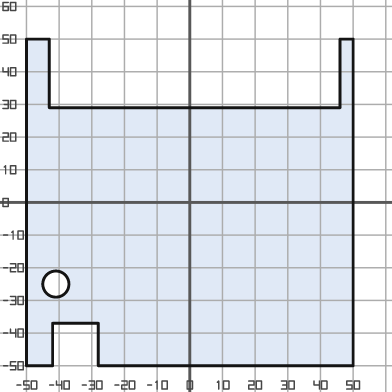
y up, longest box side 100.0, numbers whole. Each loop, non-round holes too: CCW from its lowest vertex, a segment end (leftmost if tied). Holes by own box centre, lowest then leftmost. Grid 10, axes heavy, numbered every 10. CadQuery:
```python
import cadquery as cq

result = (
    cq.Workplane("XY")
    .moveTo(-50.0, -50.0)
    .lineTo(-42.0, -50.0)
    .lineTo(-42.0, -37.0)
    .lineTo(-28.0, -37.0)
    .lineTo(-28.0, -50.0)
    .lineTo(50.0, -50.0)
    .lineTo(50.0, 50.0)
    .lineTo(46.0, 50.0)
    .lineTo(46.0, 29.0)
    .lineTo(-43.0, 29.0)
    .lineTo(-43.0, 50.0)
    .lineTo(-50.0, 50.0)
    .close()
    .moveTo(-41.0, -25.0)
    .circle(4.0)
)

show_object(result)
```